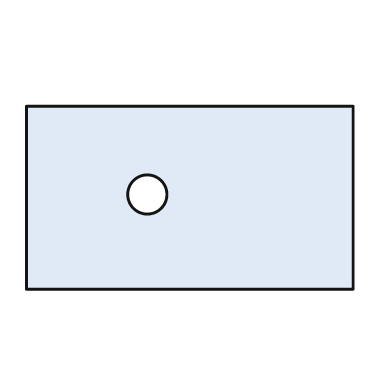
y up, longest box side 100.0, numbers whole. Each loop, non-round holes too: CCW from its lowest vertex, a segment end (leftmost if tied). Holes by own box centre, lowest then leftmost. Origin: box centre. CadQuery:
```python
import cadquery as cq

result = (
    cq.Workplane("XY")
    .moveTo(-50.0, -28.0)
    .lineTo(50.0, -28.0)
    .lineTo(50.0, 28.0)
    .lineTo(-50.0, 28.0)
    .close()
    .moveTo(-13.0, 1.0)
    .circle(6.0)
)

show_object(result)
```